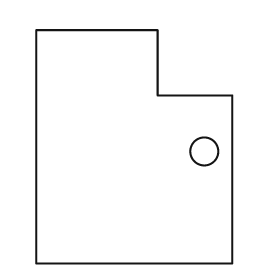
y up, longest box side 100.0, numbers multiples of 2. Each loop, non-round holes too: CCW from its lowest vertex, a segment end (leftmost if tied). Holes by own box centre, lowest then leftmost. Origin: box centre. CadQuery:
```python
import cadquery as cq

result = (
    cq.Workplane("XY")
    .moveTo(-42.0, -50.0)
    .lineTo(42.0, -50.0)
    .lineTo(42.0, 22.0)
    .lineTo(10.0, 22.0)
    .lineTo(10.0, 50.0)
    .lineTo(-42.0, 50.0)
    .close()
    .moveTo(30.0, -2.0)
    .circle(6.0)
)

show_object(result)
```